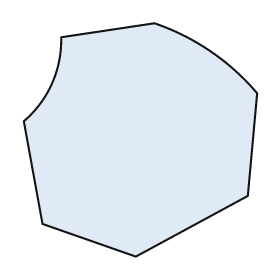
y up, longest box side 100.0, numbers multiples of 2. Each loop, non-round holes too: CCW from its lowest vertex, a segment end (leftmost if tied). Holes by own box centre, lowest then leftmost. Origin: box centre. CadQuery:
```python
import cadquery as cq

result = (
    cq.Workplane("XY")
    .moveTo(-2.0, -50.0)
    .lineTo(46.0, -24.0)
    .lineTo(50.0, 20.0)
    .threePointArc((30.0, 38.0), (6.0, 50.0))
    .lineTo(-34.0, 44.0)
    .threePointArc((-38.0, 24.0), (-50.0, 8.0))
    .lineTo(-42.0, -36.0)
    .close()
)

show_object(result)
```